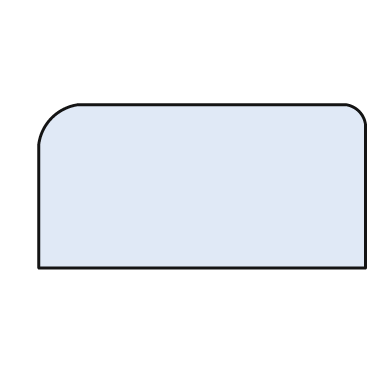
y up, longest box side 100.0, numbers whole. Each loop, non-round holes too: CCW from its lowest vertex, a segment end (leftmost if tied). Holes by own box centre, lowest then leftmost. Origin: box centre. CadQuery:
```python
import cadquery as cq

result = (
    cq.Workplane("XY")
    .moveTo(-50.0, -25.0)
    .lineTo(50.0, -25.0)
    .lineTo(50.0, 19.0)
    .threePointArc((48.0, 23.0), (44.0, 25.0))
    .lineTo(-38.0, 25.0)
    .threePointArc((-46.0, 21.0), (-50.0, 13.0))
    .close()
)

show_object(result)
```